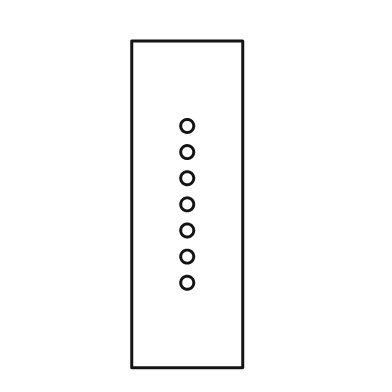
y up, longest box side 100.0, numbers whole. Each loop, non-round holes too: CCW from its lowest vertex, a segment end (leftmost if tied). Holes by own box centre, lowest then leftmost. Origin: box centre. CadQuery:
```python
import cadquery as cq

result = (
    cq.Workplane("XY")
    .moveTo(-17.0, -50.0)
    .lineTo(17.0, -50.0)
    .lineTo(17.0, 50.0)
    .lineTo(-17.0, 50.0)
    .close()
    .moveTo(0.0, -24.0)
    .circle(2.0)
    .moveTo(0.0, -16.0)
    .circle(2.0)
    .moveTo(0.0, -8.0)
    .circle(2.0)
    .moveTo(0.0, 0.0)
    .circle(2.0)
    .moveTo(0.0, 8.0)
    .circle(2.0)
    .moveTo(0.0, 16.0)
    .circle(2.0)
    .moveTo(0.0, 24.0)
    .circle(2.0)
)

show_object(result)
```